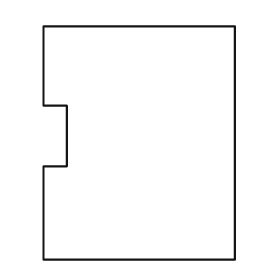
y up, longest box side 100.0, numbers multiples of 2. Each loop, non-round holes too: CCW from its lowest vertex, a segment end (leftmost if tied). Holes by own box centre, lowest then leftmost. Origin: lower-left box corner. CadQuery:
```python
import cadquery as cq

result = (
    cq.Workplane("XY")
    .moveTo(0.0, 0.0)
    .lineTo(82.0, 0.0)
    .lineTo(82.0, 100.0)
    .lineTo(0.0, 100.0)
    .lineTo(0.0, 66.0)
    .lineTo(10.0, 66.0)
    .lineTo(10.0, 40.0)
    .lineTo(0.0, 40.0)
    .close()
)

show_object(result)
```